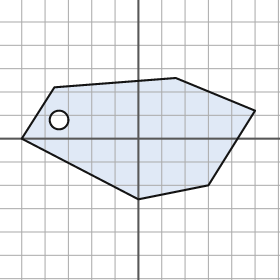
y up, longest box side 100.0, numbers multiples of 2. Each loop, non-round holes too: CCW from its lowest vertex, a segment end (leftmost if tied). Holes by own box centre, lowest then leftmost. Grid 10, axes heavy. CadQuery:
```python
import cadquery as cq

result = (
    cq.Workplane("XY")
    .moveTo(0.0, -26.0)
    .lineTo(30.0, -20.0)
    .lineTo(50.0, 12.0)
    .lineTo(16.0, 26.0)
    .lineTo(-36.0, 22.0)
    .lineTo(-50.0, 0.0)
    .close()
    .moveTo(-34.0, 8.0)
    .circle(4.0)
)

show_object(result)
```